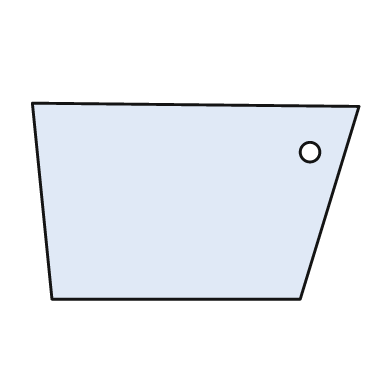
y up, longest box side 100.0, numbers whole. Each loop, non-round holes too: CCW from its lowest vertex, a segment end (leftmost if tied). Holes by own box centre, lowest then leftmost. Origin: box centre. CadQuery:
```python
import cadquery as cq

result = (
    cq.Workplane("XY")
    .moveTo(-44.0, -30.0)
    .lineTo(32.0, -30.0)
    .lineTo(50.0, 29.0)
    .lineTo(-50.0, 30.0)
    .close()
    .moveTo(35.0, 15.0)
    .circle(3.0)
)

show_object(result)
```